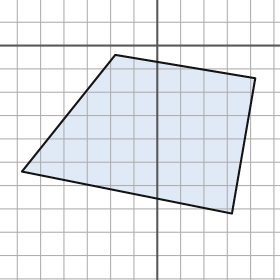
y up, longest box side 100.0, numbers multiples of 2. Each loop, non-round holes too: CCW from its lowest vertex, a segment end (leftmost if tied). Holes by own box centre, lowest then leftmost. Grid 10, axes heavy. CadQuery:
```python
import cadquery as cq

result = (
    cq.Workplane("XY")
    .moveTo(32.0, -72.0)
    .lineTo(42.0, -14.0)
    .lineTo(-18.0, -4.0)
    .lineTo(-58.0, -54.0)
    .close()
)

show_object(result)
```